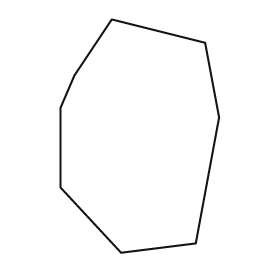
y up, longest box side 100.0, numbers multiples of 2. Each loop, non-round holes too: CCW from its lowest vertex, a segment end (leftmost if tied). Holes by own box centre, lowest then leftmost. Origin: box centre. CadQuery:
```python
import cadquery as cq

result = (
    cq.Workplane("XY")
    .moveTo(-8.0, -50.0)
    .lineTo(24.0, -46.0)
    .lineTo(34.0, 8.0)
    .lineTo(28.0, 40.0)
    .lineTo(-12.0, 50.0)
    .lineTo(-28.0, 26.0)
    .lineTo(-34.0, 12.0)
    .lineTo(-34.0, -22.0)
    .close()
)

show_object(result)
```